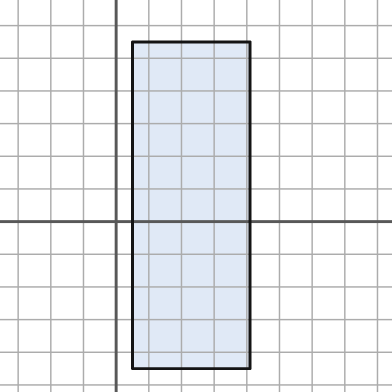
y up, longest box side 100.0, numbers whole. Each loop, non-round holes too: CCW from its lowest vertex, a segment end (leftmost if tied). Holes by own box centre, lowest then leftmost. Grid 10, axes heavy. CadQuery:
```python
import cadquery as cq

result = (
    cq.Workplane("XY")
    .moveTo(5.0, -45.0)
    .lineTo(41.0, -45.0)
    .lineTo(41.0, 55.0)
    .lineTo(5.0, 55.0)
    .close()
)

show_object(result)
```